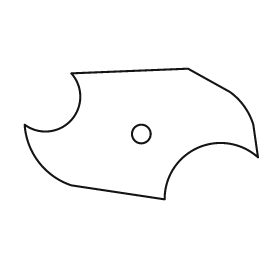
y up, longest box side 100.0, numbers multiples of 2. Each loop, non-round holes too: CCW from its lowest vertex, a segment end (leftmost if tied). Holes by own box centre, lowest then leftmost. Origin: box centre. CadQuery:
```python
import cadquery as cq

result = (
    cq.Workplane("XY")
    .moveTo(10.0, -28.0)
    .threePointArc((24.0, -6.0), (50.0, -10.0))
    .lineTo(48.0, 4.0)
    .threePointArc((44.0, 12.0), (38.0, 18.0))
    .lineTo(20.0, 28.0)
    .lineTo(-30.0, 26.0)
    .threePointArc((-30.0, 6.0), (-50.0, 4.0))
    .threePointArc((-44.0, -12.0), (-30.0, -22.0))
    .close()
    .moveTo(0.0, 0.0)
    .circle(4.0)
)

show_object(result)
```